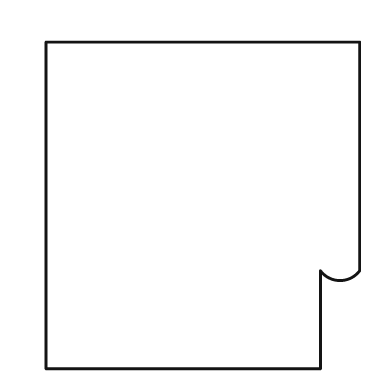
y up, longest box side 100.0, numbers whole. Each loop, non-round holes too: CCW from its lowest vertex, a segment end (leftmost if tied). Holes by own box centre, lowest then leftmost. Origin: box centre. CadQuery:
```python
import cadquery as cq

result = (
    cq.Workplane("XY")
    .moveTo(-48.0, -50.0)
    .lineTo(36.0, -50.0)
    .lineTo(36.0, -20.0)
    .threePointArc((42.0, -23.0), (48.0, -20.0))
    .lineTo(48.0, 50.0)
    .lineTo(-48.0, 50.0)
    .close()
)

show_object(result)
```